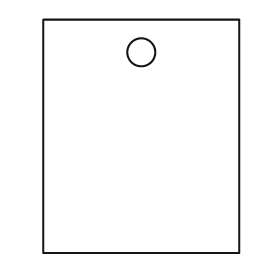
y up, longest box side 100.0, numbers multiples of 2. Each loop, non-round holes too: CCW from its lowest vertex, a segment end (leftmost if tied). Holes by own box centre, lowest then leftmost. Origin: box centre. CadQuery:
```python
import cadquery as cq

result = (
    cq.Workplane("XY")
    .moveTo(-42.0, -50.0)
    .lineTo(42.0, -50.0)
    .lineTo(42.0, 50.0)
    .lineTo(-42.0, 50.0)
    .close()
    .moveTo(0.0, 36.0)
    .circle(6.0)
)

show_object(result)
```